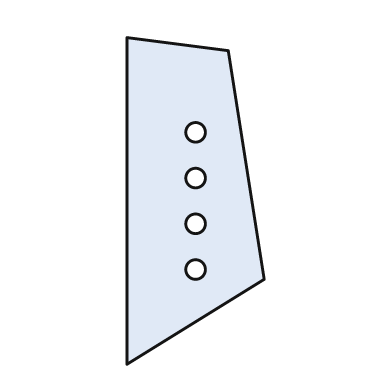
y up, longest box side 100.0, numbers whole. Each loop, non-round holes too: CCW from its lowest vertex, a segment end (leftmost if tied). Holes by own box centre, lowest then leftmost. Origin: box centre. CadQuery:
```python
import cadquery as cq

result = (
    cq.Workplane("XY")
    .moveTo(-21.0, -50.0)
    .lineTo(21.0, -24.0)
    .lineTo(10.0, 46.0)
    .lineTo(-21.0, 50.0)
    .close()
    .moveTo(0.0, -21.0)
    .circle(3.0)
    .moveTo(0.0, -7.0)
    .circle(3.0)
    .moveTo(0.0, 7.0)
    .circle(3.0)
    .moveTo(0.0, 21.0)
    .circle(3.0)
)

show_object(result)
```